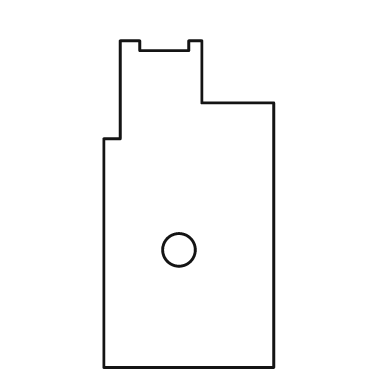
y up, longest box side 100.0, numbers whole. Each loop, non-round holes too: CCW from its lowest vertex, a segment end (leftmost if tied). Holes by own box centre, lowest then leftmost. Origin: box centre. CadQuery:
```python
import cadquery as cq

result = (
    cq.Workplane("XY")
    .moveTo(-26.0, -50.0)
    .lineTo(26.0, -50.0)
    .lineTo(26.0, 31.0)
    .lineTo(4.0, 31.0)
    .lineTo(4.0, 50.0)
    .lineTo(0.0, 50.0)
    .lineTo(0.0, 47.0)
    .lineTo(-15.0, 47.0)
    .lineTo(-15.0, 50.0)
    .lineTo(-21.0, 50.0)
    .lineTo(-21.0, 20.0)
    .lineTo(-26.0, 20.0)
    .close()
    .moveTo(-3.0, -14.0)
    .circle(5.0)
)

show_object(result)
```